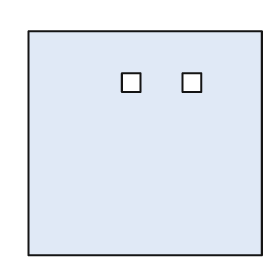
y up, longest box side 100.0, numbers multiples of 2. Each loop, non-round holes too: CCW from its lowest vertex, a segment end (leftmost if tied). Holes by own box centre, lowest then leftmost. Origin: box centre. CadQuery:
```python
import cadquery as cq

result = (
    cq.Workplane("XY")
    .moveTo(-50.0, -48.0)
    .lineTo(50.0, -48.0)
    .lineTo(50.0, 48.0)
    .lineTo(-50.0, 48.0)
    .close()
    .moveTo(-10.0, 22.0)
    .lineTo(-2.0, 22.0)
    .lineTo(-2.0, 30.0)
    .lineTo(-10.0, 30.0)
    .close()
    .moveTo(16.0, 22.0)
    .lineTo(24.0, 22.0)
    .lineTo(24.0, 30.0)
    .lineTo(16.0, 30.0)
    .close()
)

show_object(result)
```